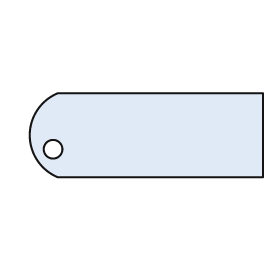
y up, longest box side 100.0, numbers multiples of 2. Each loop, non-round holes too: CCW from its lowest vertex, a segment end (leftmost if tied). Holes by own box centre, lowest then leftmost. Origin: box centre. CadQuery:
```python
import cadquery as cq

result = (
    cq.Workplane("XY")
    .moveTo(-38.0, -18.0)
    .lineTo(50.0, -18.0)
    .lineTo(50.0, 18.0)
    .lineTo(-38.0, 18.0)
    .threePointArc((-50.0, 0.0), (-38.0, -18.0))
    .close()
    .moveTo(-40.0, -6.0)
    .circle(4.0)
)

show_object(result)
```